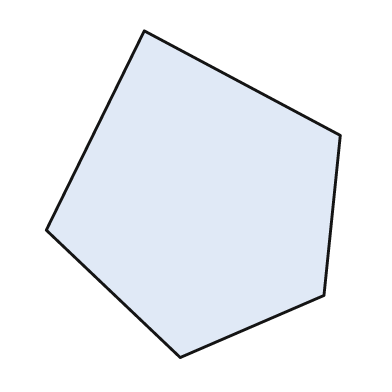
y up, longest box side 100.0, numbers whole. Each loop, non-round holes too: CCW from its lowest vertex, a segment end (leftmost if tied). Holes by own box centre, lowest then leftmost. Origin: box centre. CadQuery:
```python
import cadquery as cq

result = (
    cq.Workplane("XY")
    .moveTo(-4.0, -50.0)
    .lineTo(40.0, -31.0)
    .lineTo(45.0, 18.0)
    .lineTo(-15.0, 50.0)
    .lineTo(-45.0, -11.0)
    .close()
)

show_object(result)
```